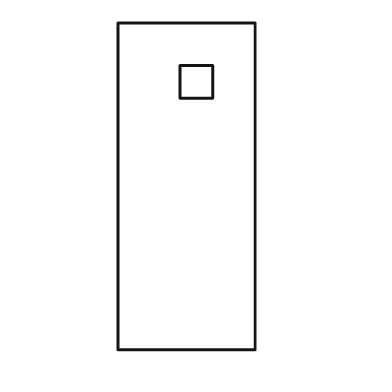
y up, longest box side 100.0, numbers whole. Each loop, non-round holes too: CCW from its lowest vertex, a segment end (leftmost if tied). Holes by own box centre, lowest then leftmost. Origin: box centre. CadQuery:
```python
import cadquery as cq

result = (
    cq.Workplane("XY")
    .moveTo(-21.0, -50.0)
    .lineTo(21.0, -50.0)
    .lineTo(21.0, 50.0)
    .lineTo(-21.0, 50.0)
    .close()
    .moveTo(-2.0, 27.0)
    .lineTo(8.0, 27.0)
    .lineTo(8.0, 37.0)
    .lineTo(-2.0, 37.0)
    .close()
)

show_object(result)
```